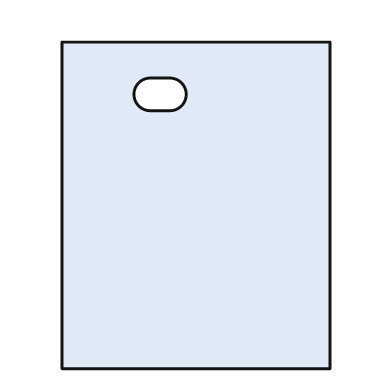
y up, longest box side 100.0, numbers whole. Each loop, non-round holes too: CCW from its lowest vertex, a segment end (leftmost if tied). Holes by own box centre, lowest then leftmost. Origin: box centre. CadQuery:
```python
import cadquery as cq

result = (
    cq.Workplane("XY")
    .moveTo(-41.0, -50.0)
    .lineTo(41.0, -50.0)
    .lineTo(41.0, 50.0)
    .lineTo(-41.0, 50.0)
    .close()
    .moveTo(-14.0, 29.0)
    .lineTo(-8.0, 29.0)
    .threePointArc((-3.0, 34.0), (-8.0, 39.0))
    .lineTo(-14.0, 39.0)
    .threePointArc((-19.0, 34.0), (-14.0, 29.0))
    .close()
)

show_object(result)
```